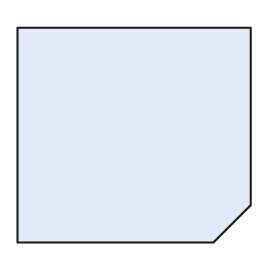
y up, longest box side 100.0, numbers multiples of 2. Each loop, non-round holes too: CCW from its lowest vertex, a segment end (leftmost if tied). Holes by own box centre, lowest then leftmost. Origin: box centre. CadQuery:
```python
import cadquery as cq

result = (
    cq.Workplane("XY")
    .moveTo(-50.0, -46.0)
    .lineTo(34.0, -46.0)
    .lineTo(50.0, -30.0)
    .lineTo(50.0, 46.0)
    .lineTo(-50.0, 46.0)
    .close()
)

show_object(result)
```